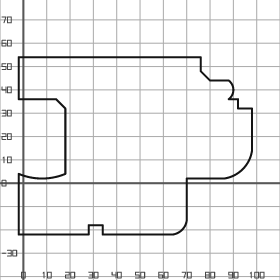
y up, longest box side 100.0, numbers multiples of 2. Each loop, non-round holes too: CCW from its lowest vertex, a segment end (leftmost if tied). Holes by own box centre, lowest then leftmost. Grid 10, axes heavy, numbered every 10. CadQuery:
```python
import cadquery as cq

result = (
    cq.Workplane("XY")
    .moveTo(-2.0, -22.0)
    .lineTo(28.0, -22.0)
    .lineTo(28.0, -18.0)
    .lineTo(34.0, -18.0)
    .lineTo(34.0, -22.0)
    .lineTo(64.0, -22.0)
    .threePointArc((68.0, -20.0), (70.0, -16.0))
    .lineTo(70.0, 2.0)
    .lineTo(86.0, 2.0)
    .threePointArc((94.0, 6.0), (98.0, 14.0))
    .lineTo(98.0, 32.0)
    .lineTo(92.0, 32.0)
    .lineTo(92.0, 36.0)
    .lineTo(88.0, 36.0)
    .threePointArc((90.0, 40.0), (88.0, 44.0))
    .lineTo(80.0, 44.0)
    .lineTo(76.0, 48.0)
    .lineTo(76.0, 54.0)
    .lineTo(-2.0, 54.0)
    .lineTo(-2.0, 36.0)
    .lineTo(14.0, 36.0)
    .lineTo(18.0, 32.0)
    .lineTo(18.0, 4.0)
    .threePointArc((8.0, 2.0), (-2.0, 4.0))
    .close()
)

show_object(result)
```